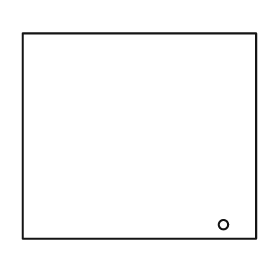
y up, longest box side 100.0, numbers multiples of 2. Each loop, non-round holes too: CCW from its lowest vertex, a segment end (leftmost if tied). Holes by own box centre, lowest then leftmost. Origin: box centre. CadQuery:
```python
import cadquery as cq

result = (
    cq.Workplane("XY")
    .moveTo(-50.0, -44.0)
    .lineTo(50.0, -44.0)
    .lineTo(50.0, 44.0)
    .lineTo(-50.0, 44.0)
    .close()
    .moveTo(36.0, -38.0)
    .circle(2.0)
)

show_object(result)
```